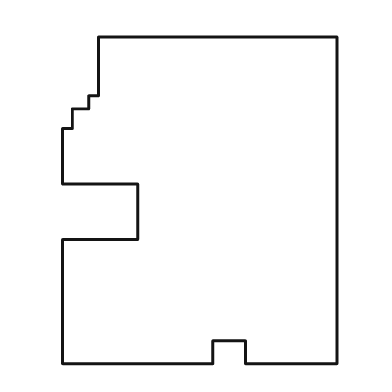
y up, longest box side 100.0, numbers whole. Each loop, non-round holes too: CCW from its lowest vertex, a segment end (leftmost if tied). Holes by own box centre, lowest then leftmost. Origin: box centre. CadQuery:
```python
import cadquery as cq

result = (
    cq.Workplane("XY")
    .moveTo(-42.0, -50.0)
    .lineTo(4.0, -50.0)
    .lineTo(4.0, -43.0)
    .lineTo(14.0, -43.0)
    .lineTo(14.0, -50.0)
    .lineTo(42.0, -50.0)
    .lineTo(42.0, 50.0)
    .lineTo(-31.0, 50.0)
    .lineTo(-31.0, 32.0)
    .lineTo(-34.0, 32.0)
    .lineTo(-34.0, 28.0)
    .lineTo(-39.0, 28.0)
    .lineTo(-39.0, 22.0)
    .lineTo(-42.0, 22.0)
    .lineTo(-42.0, 5.0)
    .lineTo(-19.0, 5.0)
    .lineTo(-19.0, -12.0)
    .lineTo(-42.0, -12.0)
    .close()
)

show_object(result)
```